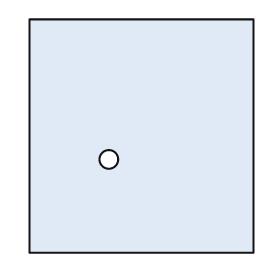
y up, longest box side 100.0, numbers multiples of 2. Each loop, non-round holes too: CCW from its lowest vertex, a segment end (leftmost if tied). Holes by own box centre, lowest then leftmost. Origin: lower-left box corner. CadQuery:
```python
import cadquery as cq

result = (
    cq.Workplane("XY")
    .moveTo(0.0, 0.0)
    .lineTo(96.0, 0.0)
    .lineTo(96.0, 100.0)
    .lineTo(0.0, 100.0)
    .close()
    .moveTo(34.0, 40.0)
    .circle(4.0)
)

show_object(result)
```